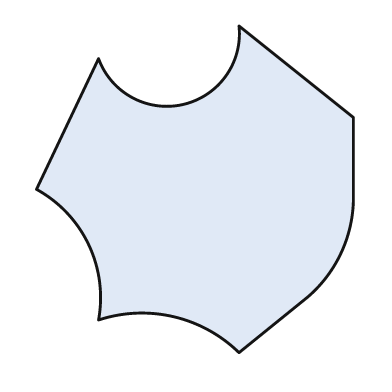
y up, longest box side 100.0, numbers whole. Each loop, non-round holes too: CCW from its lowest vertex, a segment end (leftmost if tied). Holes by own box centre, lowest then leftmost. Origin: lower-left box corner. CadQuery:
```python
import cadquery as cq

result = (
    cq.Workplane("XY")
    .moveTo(62.0, 0.0)
    .lineTo(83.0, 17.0)
    .threePointArc((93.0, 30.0), (97.0, 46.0))
    .lineTo(97.0, 72.0)
    .lineTo(62.0, 100.0)
    .threePointArc((45.0, 76.0), (19.0, 90.0))
    .lineTo(0.0, 50.0)
    .threePointArc((16.0, 33.0), (19.0, 10.0))
    .threePointArc((42.0, 11.0), (62.0, 0.0))
    .close()
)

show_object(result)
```